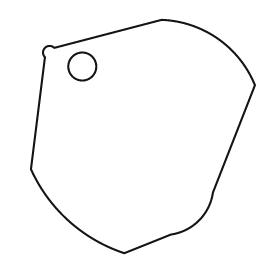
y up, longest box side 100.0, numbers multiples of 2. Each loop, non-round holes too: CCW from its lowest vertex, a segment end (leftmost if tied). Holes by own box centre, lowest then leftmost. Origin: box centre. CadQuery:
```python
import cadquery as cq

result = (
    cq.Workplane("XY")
    .moveTo(-8.0, -50.0)
    .lineTo(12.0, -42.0)
    .threePointArc((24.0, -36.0), (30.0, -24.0))
    .lineTo(48.0, 22.0)
    .threePointArc((32.0, 42.0), (8.0, 50.0))
    .lineTo(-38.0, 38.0)
    .threePointArc((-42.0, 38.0), (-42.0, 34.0))
    .lineTo(-48.0, -14.0)
    .threePointArc((-32.0, -36.0), (-8.0, -50.0))
    .close()
    .moveTo(-26.0, 30.0)
    .circle(6.0)
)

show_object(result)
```